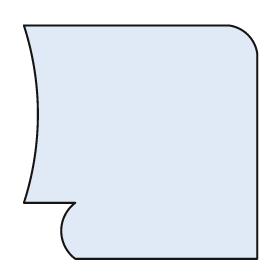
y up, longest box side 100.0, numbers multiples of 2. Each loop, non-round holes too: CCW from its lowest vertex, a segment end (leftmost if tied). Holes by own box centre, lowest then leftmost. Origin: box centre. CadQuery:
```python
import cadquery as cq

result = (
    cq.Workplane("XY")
    .moveTo(-28.0, -50.0)
    .lineTo(50.0, -50.0)
    .lineTo(50.0, 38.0)
    .threePointArc((46.0, 46.0), (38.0, 50.0))
    .lineTo(-50.0, 50.0)
    .threePointArc((-44.0, 12.0), (-50.0, -26.0))
    .lineTo(-28.0, -26.0)
    .threePointArc((-34.0, -38.0), (-28.0, -50.0))
    .close()
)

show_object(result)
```